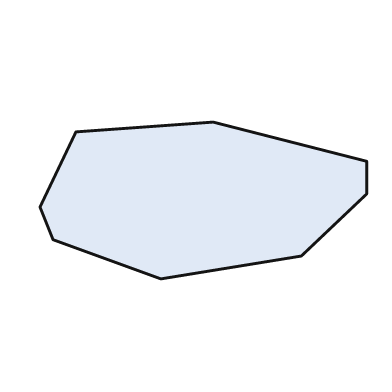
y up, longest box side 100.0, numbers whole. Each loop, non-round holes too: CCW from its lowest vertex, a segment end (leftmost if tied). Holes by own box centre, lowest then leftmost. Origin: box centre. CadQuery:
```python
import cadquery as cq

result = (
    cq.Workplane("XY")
    .moveTo(-13.0, -24.0)
    .lineTo(30.0, -17.0)
    .lineTo(50.0, 2.0)
    .lineTo(50.0, 12.0)
    .lineTo(3.0, 24.0)
    .lineTo(-39.0, 21.0)
    .lineTo(-50.0, -2.0)
    .lineTo(-46.0, -12.0)
    .close()
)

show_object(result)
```